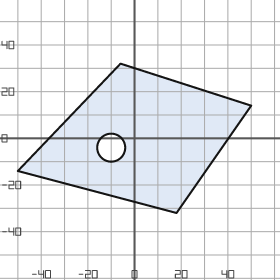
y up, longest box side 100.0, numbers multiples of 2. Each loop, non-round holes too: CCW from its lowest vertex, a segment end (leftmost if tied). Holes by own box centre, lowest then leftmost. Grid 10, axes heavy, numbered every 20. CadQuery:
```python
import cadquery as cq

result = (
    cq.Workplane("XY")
    .moveTo(18.0, -32.0)
    .lineTo(50.0, 14.0)
    .lineTo(-6.0, 32.0)
    .lineTo(-50.0, -14.0)
    .close()
    .moveTo(-10.0, -4.0)
    .circle(6.0)
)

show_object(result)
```